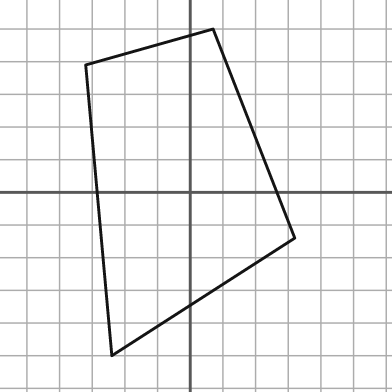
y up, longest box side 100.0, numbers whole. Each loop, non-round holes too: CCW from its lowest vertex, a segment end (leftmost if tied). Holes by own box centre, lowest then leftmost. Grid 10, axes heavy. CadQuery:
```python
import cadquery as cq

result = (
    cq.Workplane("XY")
    .moveTo(-24.0, -50.0)
    .lineTo(32.0, -14.0)
    .lineTo(7.0, 50.0)
    .lineTo(-32.0, 39.0)
    .close()
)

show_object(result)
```